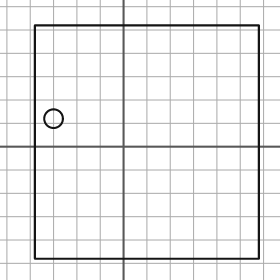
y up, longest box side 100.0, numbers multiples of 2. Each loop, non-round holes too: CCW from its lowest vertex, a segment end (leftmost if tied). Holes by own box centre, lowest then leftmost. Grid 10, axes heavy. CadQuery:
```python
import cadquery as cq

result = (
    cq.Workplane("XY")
    .moveTo(-38.0, -48.0)
    .lineTo(58.0, -48.0)
    .lineTo(58.0, 52.0)
    .lineTo(-38.0, 52.0)
    .close()
    .moveTo(-30.0, 12.0)
    .circle(4.0)
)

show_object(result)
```